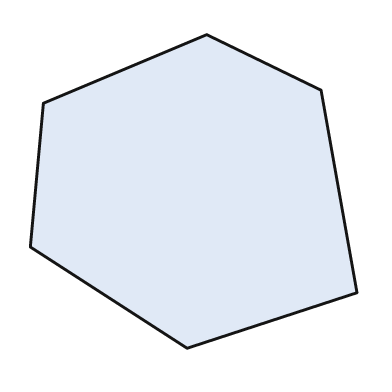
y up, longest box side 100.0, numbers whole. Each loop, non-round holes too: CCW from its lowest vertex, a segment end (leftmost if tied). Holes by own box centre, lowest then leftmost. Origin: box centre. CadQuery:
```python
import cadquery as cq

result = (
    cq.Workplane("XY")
    .moveTo(-2.0, -48.0)
    .lineTo(50.0, -31.0)
    .lineTo(39.0, 31.0)
    .lineTo(4.0, 48.0)
    .lineTo(-46.0, 27.0)
    .lineTo(-50.0, -17.0)
    .close()
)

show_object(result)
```